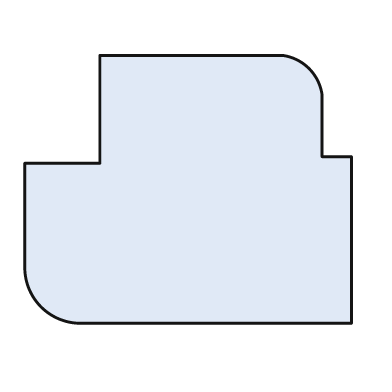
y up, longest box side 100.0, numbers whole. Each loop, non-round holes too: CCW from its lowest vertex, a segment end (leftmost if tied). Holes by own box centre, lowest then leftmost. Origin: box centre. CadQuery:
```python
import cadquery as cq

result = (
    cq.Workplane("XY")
    .moveTo(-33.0, -41.0)
    .lineTo(50.0, -41.0)
    .lineTo(50.0, 10.0)
    .lineTo(41.0, 10.0)
    .lineTo(41.0, 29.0)
    .threePointArc((37.0, 37.0), (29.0, 41.0))
    .lineTo(-27.0, 41.0)
    .lineTo(-27.0, 8.0)
    .lineTo(-50.0, 8.0)
    .lineTo(-50.0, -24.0)
    .threePointArc((-45.0, -36.0), (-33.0, -41.0))
    .close()
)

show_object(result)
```